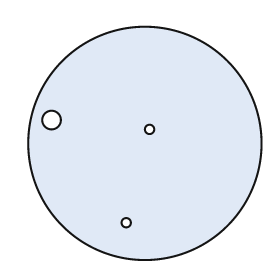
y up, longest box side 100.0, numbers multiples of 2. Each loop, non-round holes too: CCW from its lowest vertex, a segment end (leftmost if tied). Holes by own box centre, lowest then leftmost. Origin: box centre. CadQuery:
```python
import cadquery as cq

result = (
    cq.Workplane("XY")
    .moveTo(0.0, 0.0)
    .circle(50.0)
    .moveTo(-8.0, -34.0)
    .circle(2.0)
    .moveTo(2.0, 6.0)
    .circle(2.0)
    .moveTo(-40.0, 10.0)
    .circle(4.0)
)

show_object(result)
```